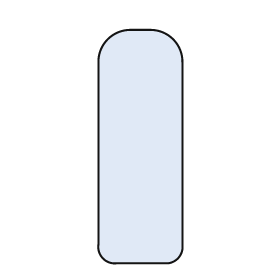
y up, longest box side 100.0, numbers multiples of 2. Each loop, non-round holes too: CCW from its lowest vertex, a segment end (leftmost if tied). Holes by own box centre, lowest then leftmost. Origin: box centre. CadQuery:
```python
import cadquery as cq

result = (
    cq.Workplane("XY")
    .moveTo(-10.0, -50.0)
    .lineTo(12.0, -50.0)
    .threePointArc((16.0, -48.0), (18.0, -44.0))
    .lineTo(18.0, 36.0)
    .threePointArc((14.0, 46.0), (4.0, 50.0))
    .lineTo(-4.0, 50.0)
    .threePointArc((-14.0, 46.0), (-18.0, 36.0))
    .lineTo(-18.0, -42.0)
    .threePointArc((-16.0, -48.0), (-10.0, -50.0))
    .close()
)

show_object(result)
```